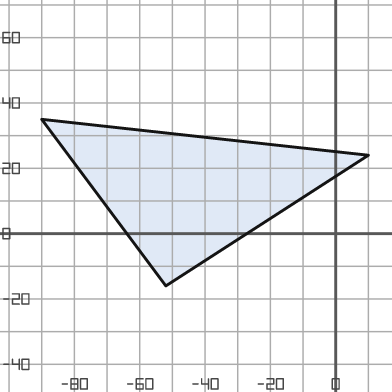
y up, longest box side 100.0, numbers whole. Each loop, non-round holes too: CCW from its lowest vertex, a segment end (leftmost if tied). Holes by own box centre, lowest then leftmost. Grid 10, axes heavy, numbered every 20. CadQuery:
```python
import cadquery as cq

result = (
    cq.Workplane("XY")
    .moveTo(-52.0, -16.0)
    .lineTo(10.0, 24.0)
    .lineTo(-90.0, 35.0)
    .close()
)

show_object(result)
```